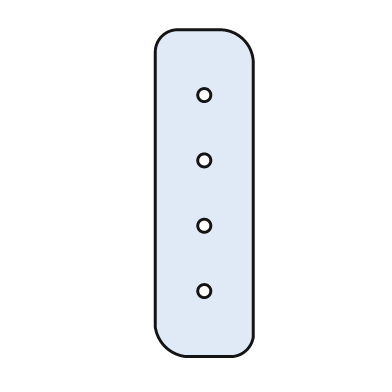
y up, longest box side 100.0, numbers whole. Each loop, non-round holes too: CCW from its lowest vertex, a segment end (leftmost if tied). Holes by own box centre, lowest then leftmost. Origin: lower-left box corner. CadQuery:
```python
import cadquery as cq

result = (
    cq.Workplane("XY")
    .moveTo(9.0, 0.0)
    .lineTo(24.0, 0.0)
    .threePointArc((28.0, 2.0), (30.0, 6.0))
    .lineTo(30.0, 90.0)
    .threePointArc((27.0, 97.0), (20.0, 100.0))
    .lineTo(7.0, 100.0)
    .threePointArc((2.0, 98.0), (0.0, 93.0))
    .lineTo(0.0, 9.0)
    .threePointArc((3.0, 3.0), (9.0, 0.0))
    .close()
    .moveTo(15.0, 20.0)
    .circle(2.0)
    .moveTo(15.0, 40.0)
    .circle(2.0)
    .moveTo(15.0, 60.0)
    .circle(2.0)
    .moveTo(15.0, 80.0)
    .circle(2.0)
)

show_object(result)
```